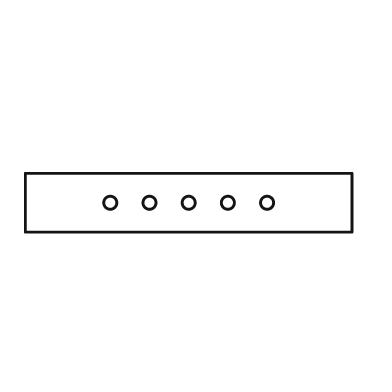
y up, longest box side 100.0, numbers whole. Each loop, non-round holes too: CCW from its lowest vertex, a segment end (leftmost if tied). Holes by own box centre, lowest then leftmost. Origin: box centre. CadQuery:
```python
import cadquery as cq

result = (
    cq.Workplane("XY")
    .moveTo(-50.0, -9.0)
    .lineTo(50.0, -9.0)
    .lineTo(50.0, 9.0)
    .lineTo(-50.0, 9.0)
    .close()
    .moveTo(-24.0, 0.0)
    .circle(2.0)
    .moveTo(-12.0, 0.0)
    .circle(2.0)
    .moveTo(0.0, 0.0)
    .circle(2.0)
    .moveTo(12.0, 0.0)
    .circle(2.0)
    .moveTo(24.0, 0.0)
    .circle(2.0)
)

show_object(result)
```